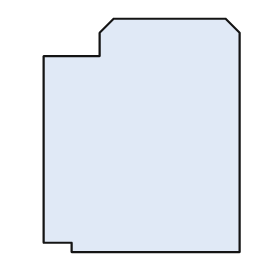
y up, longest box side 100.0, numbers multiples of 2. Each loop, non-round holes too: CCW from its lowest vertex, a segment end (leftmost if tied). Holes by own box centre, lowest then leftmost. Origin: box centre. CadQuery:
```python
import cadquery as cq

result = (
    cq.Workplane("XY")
    .moveTo(-30.0, -50.0)
    .lineTo(42.0, -50.0)
    .lineTo(42.0, 44.0)
    .lineTo(36.0, 50.0)
    .lineTo(-12.0, 50.0)
    .lineTo(-18.0, 44.0)
    .lineTo(-18.0, 34.0)
    .lineTo(-42.0, 34.0)
    .lineTo(-42.0, -46.0)
    .lineTo(-30.0, -46.0)
    .close()
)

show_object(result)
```